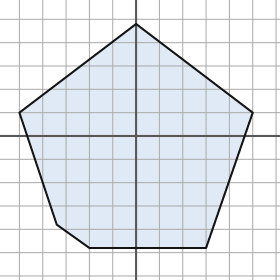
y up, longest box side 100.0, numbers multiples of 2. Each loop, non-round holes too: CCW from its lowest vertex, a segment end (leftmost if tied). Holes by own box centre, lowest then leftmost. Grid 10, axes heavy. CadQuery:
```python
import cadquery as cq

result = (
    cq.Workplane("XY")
    .moveTo(-20.0, -48.0)
    .lineTo(30.0, -48.0)
    .lineTo(50.0, 10.0)
    .lineTo(0.0, 48.0)
    .lineTo(-50.0, 10.0)
    .lineTo(-34.0, -38.0)
    .close()
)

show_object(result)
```